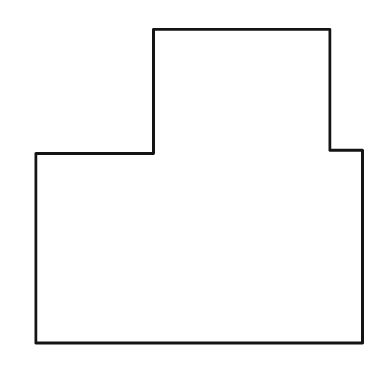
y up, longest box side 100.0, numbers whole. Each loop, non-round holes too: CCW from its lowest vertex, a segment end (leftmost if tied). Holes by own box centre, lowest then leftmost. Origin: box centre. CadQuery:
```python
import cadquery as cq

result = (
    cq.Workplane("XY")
    .moveTo(-50.0, -48.0)
    .lineTo(50.0, -48.0)
    .lineTo(50.0, 11.0)
    .lineTo(40.0, 11.0)
    .lineTo(40.0, 48.0)
    .lineTo(-14.0, 48.0)
    .lineTo(-14.0, 10.0)
    .lineTo(-50.0, 10.0)
    .close()
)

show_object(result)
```